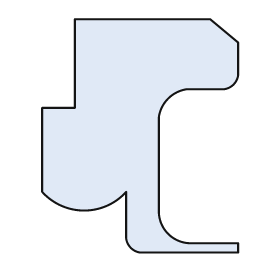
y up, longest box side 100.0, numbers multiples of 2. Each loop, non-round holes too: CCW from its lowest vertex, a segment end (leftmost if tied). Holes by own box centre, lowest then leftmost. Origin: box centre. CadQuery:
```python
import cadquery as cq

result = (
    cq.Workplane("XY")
    .moveTo(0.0, -50.0)
    .lineTo(42.0, -50.0)
    .lineTo(42.0, -46.0)
    .lineTo(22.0, -46.0)
    .threePointArc((12.0, -42.0), (8.0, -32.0))
    .lineTo(8.0, 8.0)
    .threePointArc((12.0, 16.0), (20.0, 20.0))
    .lineTo(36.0, 20.0)
    .threePointArc((40.0, 22.0), (42.0, 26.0))
    .lineTo(42.0, 40.0)
    .lineTo(30.0, 50.0)
    .lineTo(-28.0, 50.0)
    .lineTo(-28.0, 12.0)
    .lineTo(-42.0, 12.0)
    .lineTo(-42.0, -24.0)
    .threePointArc((-24.0, -32.0), (-6.0, -24.0))
    .lineTo(-6.0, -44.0)
    .threePointArc((-4.0, -48.0), (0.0, -50.0))
    .close()
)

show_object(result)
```